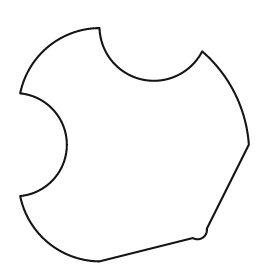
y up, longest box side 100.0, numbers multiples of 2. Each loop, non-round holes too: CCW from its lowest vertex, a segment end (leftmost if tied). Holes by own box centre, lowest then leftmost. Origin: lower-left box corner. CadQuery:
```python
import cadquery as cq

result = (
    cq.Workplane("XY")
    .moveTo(34.0, 0.0)
    .lineTo(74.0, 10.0)
    .threePointArc((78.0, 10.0), (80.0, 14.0))
    .lineTo(98.0, 50.0)
    .threePointArc((92.0, 72.0), (78.0, 90.0))
    .threePointArc((52.0, 78.0), (34.0, 100.0))
    .threePointArc((12.0, 92.0), (0.0, 72.0))
    .threePointArc((20.0, 50.0), (0.0, 28.0))
    .threePointArc((12.0, 8.0), (34.0, 0.0))
    .close()
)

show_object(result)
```